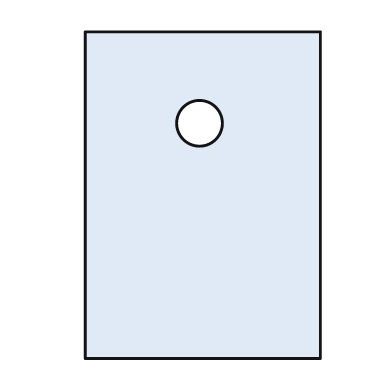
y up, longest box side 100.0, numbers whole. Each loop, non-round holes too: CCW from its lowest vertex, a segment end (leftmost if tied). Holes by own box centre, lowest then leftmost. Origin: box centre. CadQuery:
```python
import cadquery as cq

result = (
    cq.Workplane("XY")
    .moveTo(-36.0, -50.0)
    .lineTo(36.0, -50.0)
    .lineTo(36.0, 50.0)
    .lineTo(-36.0, 50.0)
    .close()
    .moveTo(-1.0, 22.0)
    .circle(7.0)
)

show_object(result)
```